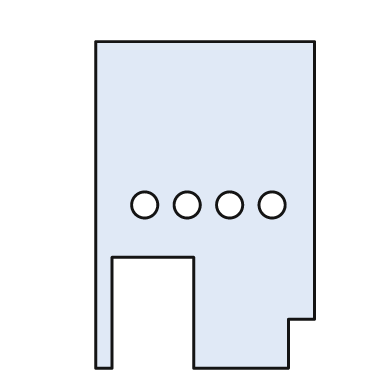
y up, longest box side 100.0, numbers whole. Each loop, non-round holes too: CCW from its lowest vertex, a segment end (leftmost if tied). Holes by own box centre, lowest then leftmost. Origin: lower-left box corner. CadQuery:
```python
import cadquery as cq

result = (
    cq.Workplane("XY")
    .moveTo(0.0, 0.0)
    .lineTo(5.0, 0.0)
    .lineTo(5.0, 34.0)
    .lineTo(30.0, 34.0)
    .lineTo(30.0, 0.0)
    .lineTo(59.0, 0.0)
    .lineTo(59.0, 15.0)
    .lineTo(67.0, 15.0)
    .lineTo(67.0, 100.0)
    .lineTo(0.0, 100.0)
    .close()
    .moveTo(15.0, 50.0)
    .circle(4.0)
    .moveTo(28.0, 50.0)
    .circle(4.0)
    .moveTo(41.0, 50.0)
    .circle(4.0)
    .moveTo(54.0, 50.0)
    .circle(4.0)
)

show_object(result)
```